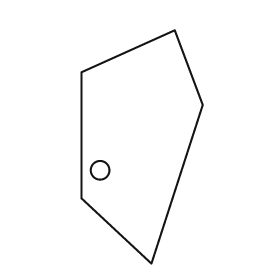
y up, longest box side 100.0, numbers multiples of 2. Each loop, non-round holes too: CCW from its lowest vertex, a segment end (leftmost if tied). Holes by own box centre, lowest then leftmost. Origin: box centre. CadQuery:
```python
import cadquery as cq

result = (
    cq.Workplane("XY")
    .moveTo(4.0, -50.0)
    .lineTo(26.0, 18.0)
    .lineTo(14.0, 50.0)
    .lineTo(-26.0, 32.0)
    .lineTo(-26.0, -22.0)
    .close()
    .moveTo(-18.0, -10.0)
    .circle(4.0)
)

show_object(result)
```